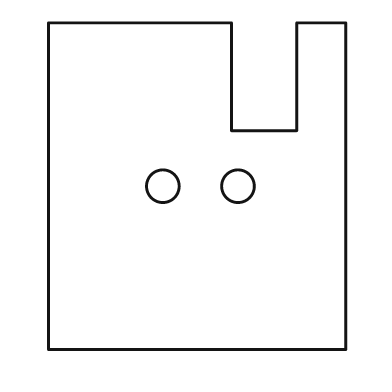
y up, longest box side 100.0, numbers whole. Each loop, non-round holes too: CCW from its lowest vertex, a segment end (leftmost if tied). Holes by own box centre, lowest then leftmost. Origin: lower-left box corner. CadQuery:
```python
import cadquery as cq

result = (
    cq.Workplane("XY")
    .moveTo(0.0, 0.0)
    .lineTo(91.0, 0.0)
    .lineTo(91.0, 100.0)
    .lineTo(76.0, 100.0)
    .lineTo(76.0, 67.0)
    .lineTo(56.0, 67.0)
    .lineTo(56.0, 100.0)
    .lineTo(0.0, 100.0)
    .close()
    .moveTo(35.0, 50.0)
    .circle(5.0)
    .moveTo(58.0, 50.0)
    .circle(5.0)
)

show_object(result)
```